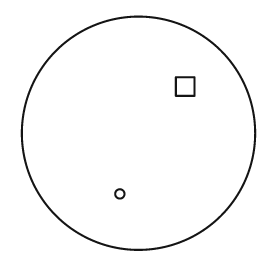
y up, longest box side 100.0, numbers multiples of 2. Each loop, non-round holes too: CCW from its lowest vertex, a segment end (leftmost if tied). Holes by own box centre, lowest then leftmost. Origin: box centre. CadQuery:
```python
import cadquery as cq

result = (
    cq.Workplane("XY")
    .moveTo(0.0, 0.0)
    .circle(50.0)
    .moveTo(-8.0, -26.0)
    .circle(2.0)
    .moveTo(16.0, 16.0)
    .lineTo(24.0, 16.0)
    .lineTo(24.0, 24.0)
    .lineTo(16.0, 24.0)
    .close()
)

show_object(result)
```